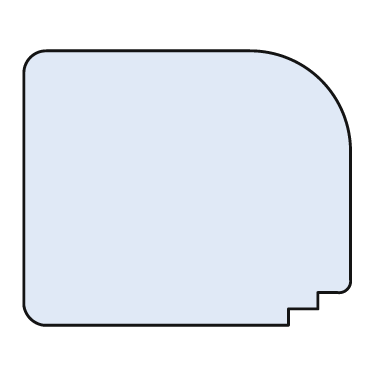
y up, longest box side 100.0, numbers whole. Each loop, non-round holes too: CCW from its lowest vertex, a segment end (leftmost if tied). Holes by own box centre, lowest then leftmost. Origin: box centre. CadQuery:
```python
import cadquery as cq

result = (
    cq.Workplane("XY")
    .moveTo(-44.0, -42.0)
    .lineTo(31.0, -42.0)
    .lineTo(31.0, -37.0)
    .lineTo(40.0, -37.0)
    .lineTo(40.0, -32.0)
    .lineTo(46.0, -32.0)
    .threePointArc((49.0, -31.0), (50.0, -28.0))
    .lineTo(50.0, 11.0)
    .threePointArc((41.0, 33.0), (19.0, 42.0))
    .lineTo(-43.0, 42.0)
    .threePointArc((-48.0, 40.0), (-50.0, 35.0))
    .lineTo(-50.0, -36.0)
    .threePointArc((-48.0, -40.0), (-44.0, -42.0))
    .close()
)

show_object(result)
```